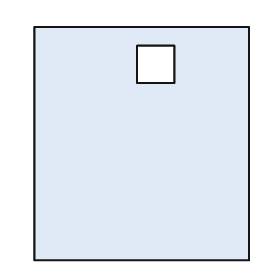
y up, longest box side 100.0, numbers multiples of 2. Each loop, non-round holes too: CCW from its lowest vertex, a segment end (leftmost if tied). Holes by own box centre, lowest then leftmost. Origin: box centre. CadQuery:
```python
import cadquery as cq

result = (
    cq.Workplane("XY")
    .moveTo(-46.0, -50.0)
    .lineTo(46.0, -50.0)
    .lineTo(46.0, 50.0)
    .lineTo(-46.0, 50.0)
    .close()
    .moveTo(-2.0, 26.0)
    .lineTo(14.0, 26.0)
    .lineTo(14.0, 42.0)
    .lineTo(-2.0, 42.0)
    .close()
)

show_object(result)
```